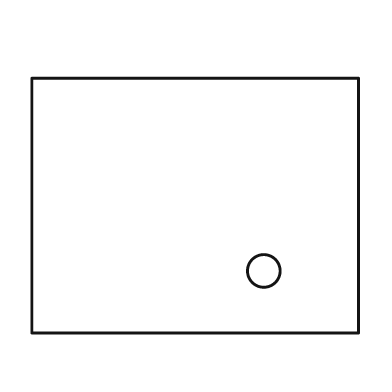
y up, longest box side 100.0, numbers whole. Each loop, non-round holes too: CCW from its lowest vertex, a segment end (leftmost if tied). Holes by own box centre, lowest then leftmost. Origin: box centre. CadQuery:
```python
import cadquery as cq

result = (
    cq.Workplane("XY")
    .moveTo(-50.0, -39.0)
    .lineTo(50.0, -39.0)
    .lineTo(50.0, 39.0)
    .lineTo(-50.0, 39.0)
    .close()
    .moveTo(21.0, -20.0)
    .circle(5.0)
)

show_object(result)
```